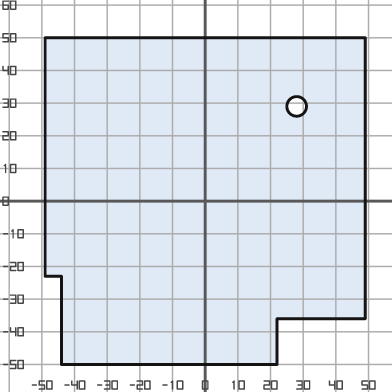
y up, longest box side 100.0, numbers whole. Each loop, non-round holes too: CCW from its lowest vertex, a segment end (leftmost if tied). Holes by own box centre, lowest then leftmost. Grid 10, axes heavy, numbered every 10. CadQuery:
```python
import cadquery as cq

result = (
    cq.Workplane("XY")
    .moveTo(-44.0, -50.0)
    .lineTo(22.0, -50.0)
    .lineTo(22.0, -36.0)
    .lineTo(49.0, -36.0)
    .lineTo(49.0, 50.0)
    .lineTo(-49.0, 50.0)
    .lineTo(-49.0, -23.0)
    .lineTo(-44.0, -23.0)
    .close()
    .moveTo(28.0, 29.0)
    .circle(3.0)
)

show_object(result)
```